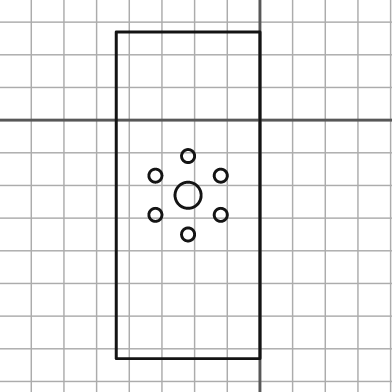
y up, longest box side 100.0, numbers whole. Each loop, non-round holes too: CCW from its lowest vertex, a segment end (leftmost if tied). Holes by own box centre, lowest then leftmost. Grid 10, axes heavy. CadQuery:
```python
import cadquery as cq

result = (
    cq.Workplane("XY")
    .moveTo(-44.0, -73.0)
    .lineTo(0.0, -73.0)
    .lineTo(0.0, 27.0)
    .lineTo(-44.0, 27.0)
    .close()
    .moveTo(-22.0, -35.0)
    .circle(2.0)
    .moveTo(-32.0, -29.0)
    .circle(2.0)
    .moveTo(-12.0, -29.0)
    .circle(2.0)
    .moveTo(-22.0, -23.0)
    .circle(4.0)
    .moveTo(-32.0, -17.0)
    .circle(2.0)
    .moveTo(-12.0, -17.0)
    .circle(2.0)
    .moveTo(-22.0, -11.0)
    .circle(2.0)
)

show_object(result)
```